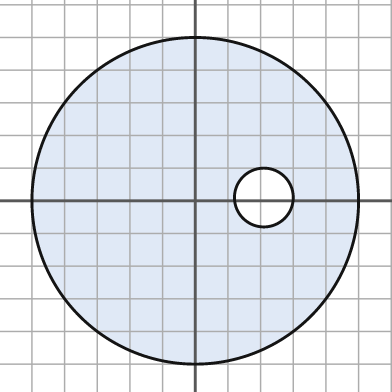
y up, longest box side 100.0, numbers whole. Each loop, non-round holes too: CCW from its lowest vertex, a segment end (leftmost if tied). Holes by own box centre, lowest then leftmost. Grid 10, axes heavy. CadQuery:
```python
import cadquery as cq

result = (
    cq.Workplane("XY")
    .moveTo(0.0, 0.0)
    .circle(50.0)
    .moveTo(21.0, 1.0)
    .circle(9.0)
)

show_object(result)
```